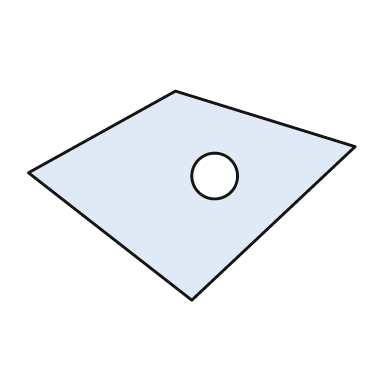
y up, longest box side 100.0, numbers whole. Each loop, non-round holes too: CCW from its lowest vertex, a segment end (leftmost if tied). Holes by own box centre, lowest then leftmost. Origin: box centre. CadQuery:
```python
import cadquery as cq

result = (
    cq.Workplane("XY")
    .moveTo(0.0, -32.0)
    .lineTo(50.0, 15.0)
    .lineTo(-5.0, 32.0)
    .lineTo(-50.0, 7.0)
    .close()
    .moveTo(7.0, 6.0)
    .circle(7.0)
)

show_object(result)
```